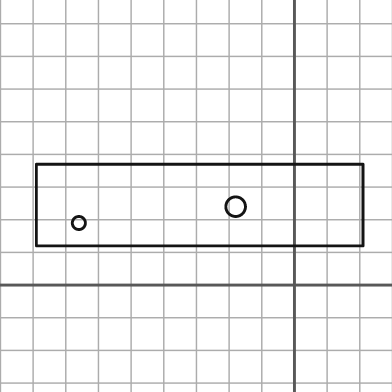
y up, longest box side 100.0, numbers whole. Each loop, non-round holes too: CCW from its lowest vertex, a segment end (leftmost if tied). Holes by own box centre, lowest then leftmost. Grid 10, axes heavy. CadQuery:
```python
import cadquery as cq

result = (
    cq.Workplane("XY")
    .moveTo(-79.0, 12.0)
    .lineTo(21.0, 12.0)
    .lineTo(21.0, 37.0)
    .lineTo(-79.0, 37.0)
    .close()
    .moveTo(-66.0, 19.0)
    .circle(2.0)
    .moveTo(-18.0, 24.0)
    .circle(3.0)
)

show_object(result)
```